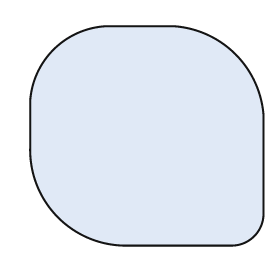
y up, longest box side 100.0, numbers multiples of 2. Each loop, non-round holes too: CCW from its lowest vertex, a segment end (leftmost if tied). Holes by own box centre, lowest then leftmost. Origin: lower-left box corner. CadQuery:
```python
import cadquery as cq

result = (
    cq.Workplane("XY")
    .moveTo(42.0, 0.0)
    .lineTo(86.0, 0.0)
    .threePointArc((96.0, 4.0), (100.0, 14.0))
    .lineTo(100.0, 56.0)
    .threePointArc((88.0, 82.0), (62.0, 94.0))
    .lineTo(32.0, 94.0)
    .threePointArc((10.0, 84.0), (0.0, 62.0))
    .lineTo(0.0, 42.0)
    .threePointArc((12.0, 12.0), (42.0, 0.0))
    .close()
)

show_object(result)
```